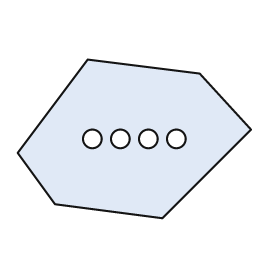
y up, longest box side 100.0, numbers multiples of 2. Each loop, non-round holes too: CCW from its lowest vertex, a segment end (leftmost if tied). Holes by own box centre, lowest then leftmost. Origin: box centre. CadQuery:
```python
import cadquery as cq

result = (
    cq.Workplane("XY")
    .moveTo(12.0, -34.0)
    .lineTo(50.0, 4.0)
    .lineTo(28.0, 28.0)
    .lineTo(-20.0, 34.0)
    .lineTo(-50.0, -6.0)
    .lineTo(-34.0, -28.0)
    .close()
    .moveTo(-18.0, 0.0)
    .circle(4.0)
    .moveTo(-6.0, 0.0)
    .circle(4.0)
    .moveTo(6.0, 0.0)
    .circle(4.0)
    .moveTo(18.0, 0.0)
    .circle(4.0)
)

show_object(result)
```